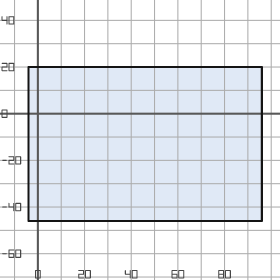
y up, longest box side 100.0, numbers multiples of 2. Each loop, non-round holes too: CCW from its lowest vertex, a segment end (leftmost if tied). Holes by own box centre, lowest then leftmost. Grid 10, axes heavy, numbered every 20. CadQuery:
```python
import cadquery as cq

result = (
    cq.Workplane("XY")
    .moveTo(-4.0, -46.0)
    .lineTo(96.0, -46.0)
    .lineTo(96.0, 20.0)
    .lineTo(-4.0, 20.0)
    .close()
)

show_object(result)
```